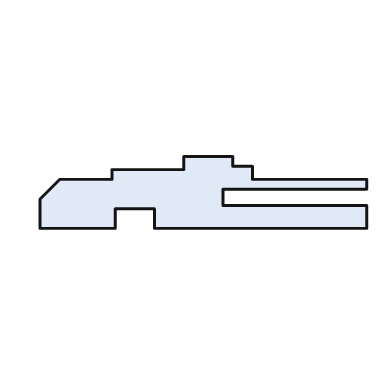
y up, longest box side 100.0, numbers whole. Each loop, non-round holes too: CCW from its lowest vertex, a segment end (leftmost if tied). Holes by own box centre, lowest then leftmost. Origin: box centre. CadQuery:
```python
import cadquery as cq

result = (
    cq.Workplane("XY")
    .moveTo(-50.0, -11.0)
    .lineTo(-27.0, -11.0)
    .lineTo(-27.0, -5.0)
    .lineTo(-15.0, -5.0)
    .lineTo(-15.0, -11.0)
    .lineTo(50.0, -11.0)
    .lineTo(50.0, -4.0)
    .lineTo(6.0, -4.0)
    .lineTo(6.0, 1.0)
    .lineTo(50.0, 1.0)
    .lineTo(50.0, 4.0)
    .lineTo(15.0, 4.0)
    .lineTo(15.0, 8.0)
    .lineTo(9.0, 8.0)
    .lineTo(9.0, 11.0)
    .lineTo(-6.0, 11.0)
    .lineTo(-6.0, 7.0)
    .lineTo(-28.0, 7.0)
    .lineTo(-28.0, 4.0)
    .lineTo(-44.0, 4.0)
    .lineTo(-50.0, -2.0)
    .close()
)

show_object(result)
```